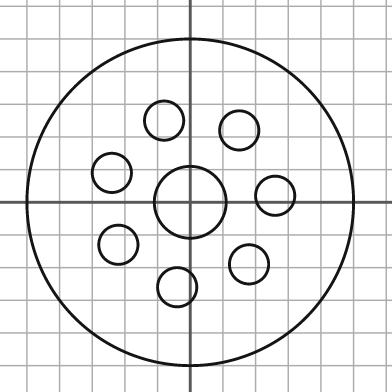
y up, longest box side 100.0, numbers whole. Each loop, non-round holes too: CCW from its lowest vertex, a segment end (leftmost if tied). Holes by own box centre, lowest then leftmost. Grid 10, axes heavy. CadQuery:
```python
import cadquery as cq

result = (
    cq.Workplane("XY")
    .moveTo(0.0, 0.0)
    .circle(50.0)
    .moveTo(-4.0, -26.0)
    .circle(6.0)
    .moveTo(18.0, -19.0)
    .circle(6.0)
    .moveTo(-22.0, -13.0)
    .circle(6.0)
    .moveTo(0.0, 0.0)
    .circle(11.0)
    .moveTo(26.0, 2.0)
    .circle(6.0)
    .moveTo(-24.0, 9.0)
    .circle(6.0)
    .moveTo(15.0, 22.0)
    .circle(6.0)
    .moveTo(-8.0, 25.0)
    .circle(6.0)
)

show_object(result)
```